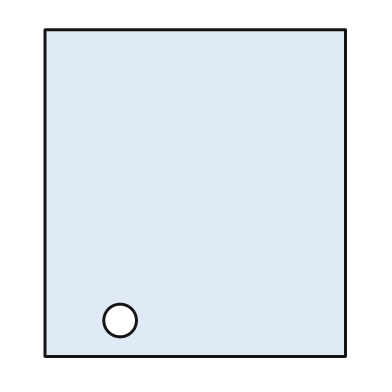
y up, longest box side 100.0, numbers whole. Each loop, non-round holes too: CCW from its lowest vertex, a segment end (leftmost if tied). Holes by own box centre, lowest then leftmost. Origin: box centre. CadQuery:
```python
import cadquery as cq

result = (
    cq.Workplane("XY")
    .moveTo(-46.0, -50.0)
    .lineTo(46.0, -50.0)
    .lineTo(46.0, 50.0)
    .lineTo(-46.0, 50.0)
    .close()
    .moveTo(-23.0, -39.0)
    .circle(5.0)
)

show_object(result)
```